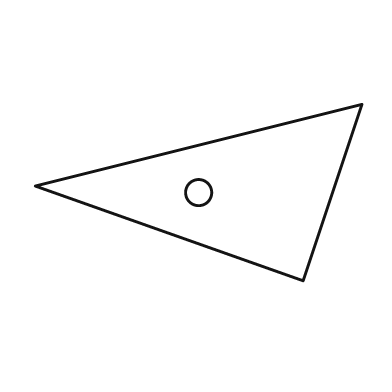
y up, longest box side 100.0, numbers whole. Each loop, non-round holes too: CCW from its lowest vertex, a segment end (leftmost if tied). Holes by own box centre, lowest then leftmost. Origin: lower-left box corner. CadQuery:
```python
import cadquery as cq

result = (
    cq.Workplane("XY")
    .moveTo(82.0, 0.0)
    .lineTo(100.0, 54.0)
    .lineTo(0.0, 29.0)
    .close()
    .moveTo(50.0, 27.0)
    .circle(4.0)
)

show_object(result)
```